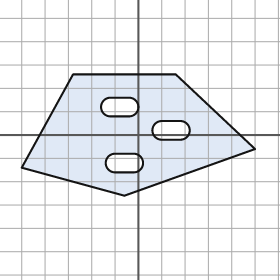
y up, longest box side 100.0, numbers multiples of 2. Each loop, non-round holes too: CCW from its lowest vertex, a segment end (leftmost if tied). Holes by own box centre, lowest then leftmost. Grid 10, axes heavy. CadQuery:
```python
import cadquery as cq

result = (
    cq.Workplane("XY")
    .moveTo(-6.0, -26.0)
    .lineTo(50.0, -6.0)
    .lineTo(16.0, 26.0)
    .lineTo(-28.0, 26.0)
    .lineTo(-50.0, -14.0)
    .close()
    .moveTo(-10.0, -16.0)
    .lineTo(-2.0, -16.0)
    .threePointArc((2.0, -12.0), (-2.0, -8.0))
    .lineTo(-10.0, -8.0)
    .threePointArc((-14.0, -12.0), (-10.0, -16.0))
    .close()
    .moveTo(10.0, -2.0)
    .lineTo(18.0, -2.0)
    .threePointArc((22.0, 2.0), (18.0, 6.0))
    .lineTo(10.0, 6.0)
    .threePointArc((6.0, 2.0), (10.0, -2.0))
    .close()
    .moveTo(-12.0, 8.0)
    .lineTo(-4.0, 8.0)
    .threePointArc((0.0, 12.0), (-4.0, 16.0))
    .lineTo(-12.0, 16.0)
    .threePointArc((-16.0, 12.0), (-12.0, 8.0))
    .close()
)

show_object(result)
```